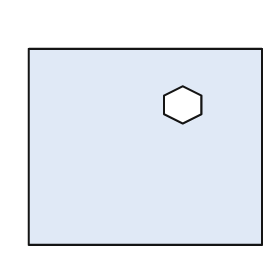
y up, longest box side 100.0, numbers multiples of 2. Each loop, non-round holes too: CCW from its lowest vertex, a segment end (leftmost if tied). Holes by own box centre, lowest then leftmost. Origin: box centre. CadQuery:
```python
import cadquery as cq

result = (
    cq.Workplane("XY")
    .moveTo(-50.0, -42.0)
    .lineTo(50.0, -42.0)
    .lineTo(50.0, 42.0)
    .lineTo(-50.0, 42.0)
    .close()
    .moveTo(16.0, 10.0)
    .lineTo(24.0, 14.0)
    .lineTo(24.0, 22.0)
    .lineTo(16.0, 26.0)
    .lineTo(8.0, 22.0)
    .lineTo(8.0, 14.0)
    .close()
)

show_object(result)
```